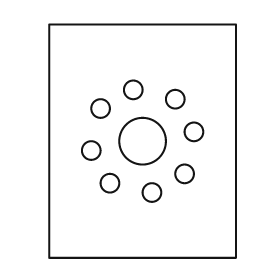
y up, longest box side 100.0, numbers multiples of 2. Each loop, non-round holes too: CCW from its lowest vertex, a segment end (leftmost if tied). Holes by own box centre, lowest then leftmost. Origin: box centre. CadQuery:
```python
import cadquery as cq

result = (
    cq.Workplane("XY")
    .moveTo(-40.0, -50.0)
    .lineTo(40.0, -50.0)
    .lineTo(40.0, 50.0)
    .lineTo(-40.0, 50.0)
    .close()
    .moveTo(4.0, -22.0)
    .circle(4.0)
    .moveTo(-14.0, -18.0)
    .circle(4.0)
    .moveTo(18.0, -14.0)
    .circle(4.0)
    .moveTo(-22.0, -4.0)
    .circle(4.0)
    .moveTo(0.0, 0.0)
    .circle(10.0)
    .moveTo(22.0, 4.0)
    .circle(4.0)
    .moveTo(-18.0, 14.0)
    .circle(4.0)
    .moveTo(14.0, 18.0)
    .circle(4.0)
    .moveTo(-4.0, 22.0)
    .circle(4.0)
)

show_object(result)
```